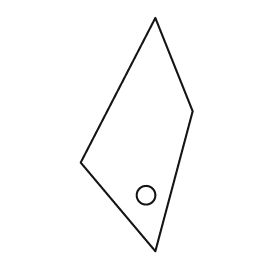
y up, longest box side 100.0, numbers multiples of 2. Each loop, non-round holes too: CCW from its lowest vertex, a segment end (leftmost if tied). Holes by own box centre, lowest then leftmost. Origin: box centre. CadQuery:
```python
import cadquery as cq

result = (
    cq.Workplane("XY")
    .moveTo(8.0, -50.0)
    .lineTo(24.0, 10.0)
    .lineTo(8.0, 50.0)
    .lineTo(-24.0, -12.0)
    .close()
    .moveTo(4.0, -26.0)
    .circle(4.0)
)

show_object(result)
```